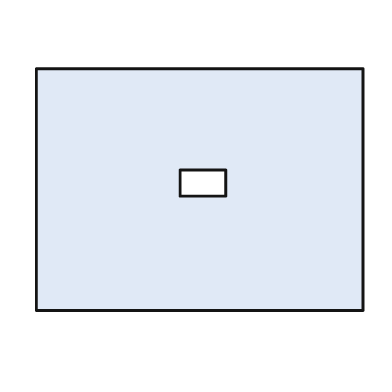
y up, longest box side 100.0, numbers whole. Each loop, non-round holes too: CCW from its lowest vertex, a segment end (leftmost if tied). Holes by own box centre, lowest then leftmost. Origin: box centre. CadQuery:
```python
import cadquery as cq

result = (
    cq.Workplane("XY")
    .moveTo(-50.0, -37.0)
    .lineTo(50.0, -37.0)
    .lineTo(50.0, 37.0)
    .lineTo(-50.0, 37.0)
    .close()
    .moveTo(-6.0, -2.0)
    .lineTo(8.0, -2.0)
    .lineTo(8.0, 6.0)
    .lineTo(-6.0, 6.0)
    .close()
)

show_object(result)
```